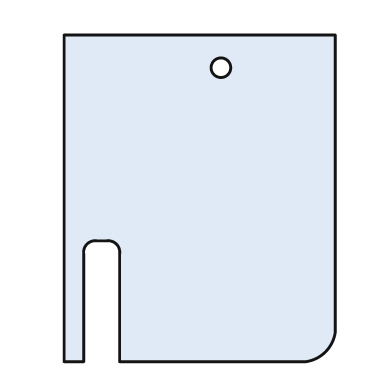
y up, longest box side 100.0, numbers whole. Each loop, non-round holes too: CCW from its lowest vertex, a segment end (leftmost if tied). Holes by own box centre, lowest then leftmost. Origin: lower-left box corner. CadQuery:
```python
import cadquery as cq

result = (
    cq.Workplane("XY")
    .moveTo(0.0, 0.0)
    .lineTo(6.0, 0.0)
    .lineTo(6.0, 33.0)
    .threePointArc((7.0, 36.0), (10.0, 37.0))
    .lineTo(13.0, 37.0)
    .threePointArc((16.0, 36.0), (17.0, 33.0))
    .lineTo(17.0, 0.0)
    .lineTo(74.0, 0.0)
    .threePointArc((80.0, 3.0), (83.0, 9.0))
    .lineTo(83.0, 100.0)
    .lineTo(0.0, 100.0)
    .close()
    .moveTo(48.0, 90.0)
    .circle(3.0)
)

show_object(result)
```